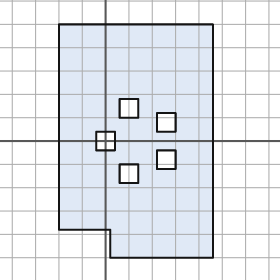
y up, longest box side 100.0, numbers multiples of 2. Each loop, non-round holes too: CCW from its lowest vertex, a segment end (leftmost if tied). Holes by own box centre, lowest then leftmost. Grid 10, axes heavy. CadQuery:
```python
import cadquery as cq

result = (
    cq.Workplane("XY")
    .moveTo(2.0, -50.0)
    .lineTo(46.0, -50.0)
    .lineTo(46.0, 50.0)
    .lineTo(-20.0, 50.0)
    .lineTo(-20.0, -38.0)
    .lineTo(2.0, -38.0)
    .close()
    .moveTo(6.0, -18.0)
    .lineTo(14.0, -18.0)
    .lineTo(14.0, -10.0)
    .lineTo(6.0, -10.0)
    .close()
    .moveTo(22.0, -12.0)
    .lineTo(30.0, -12.0)
    .lineTo(30.0, -4.0)
    .lineTo(22.0, -4.0)
    .close()
    .moveTo(-4.0, -4.0)
    .lineTo(4.0, -4.0)
    .lineTo(4.0, 4.0)
    .lineTo(-4.0, 4.0)
    .close()
    .moveTo(22.0, 4.0)
    .lineTo(30.0, 4.0)
    .lineTo(30.0, 12.0)
    .lineTo(22.0, 12.0)
    .close()
    .moveTo(6.0, 10.0)
    .lineTo(14.0, 10.0)
    .lineTo(14.0, 18.0)
    .lineTo(6.0, 18.0)
    .close()
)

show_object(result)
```